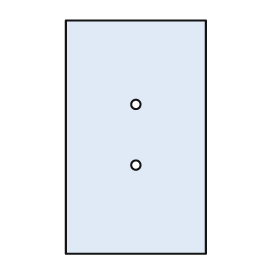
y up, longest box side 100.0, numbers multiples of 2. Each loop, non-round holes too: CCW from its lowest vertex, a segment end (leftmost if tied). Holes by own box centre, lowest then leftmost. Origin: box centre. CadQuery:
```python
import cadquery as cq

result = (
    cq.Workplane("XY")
    .moveTo(-30.0, -50.0)
    .lineTo(30.0, -50.0)
    .lineTo(30.0, 50.0)
    .lineTo(-30.0, 50.0)
    .close()
    .moveTo(0.0, -12.0)
    .circle(2.0)
    .moveTo(0.0, 14.0)
    .circle(2.0)
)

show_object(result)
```